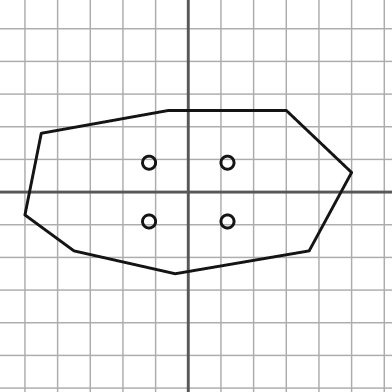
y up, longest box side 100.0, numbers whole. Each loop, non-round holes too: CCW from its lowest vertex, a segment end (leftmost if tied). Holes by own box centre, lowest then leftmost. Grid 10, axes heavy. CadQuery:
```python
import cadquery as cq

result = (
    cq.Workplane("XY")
    .moveTo(-4.0, -25.0)
    .lineTo(37.0, -18.0)
    .lineTo(50.0, 6.0)
    .lineTo(30.0, 25.0)
    .lineTo(-6.0, 25.0)
    .lineTo(-45.0, 18.0)
    .lineTo(-50.0, -7.0)
    .lineTo(-35.0, -18.0)
    .close()
    .moveTo(-12.0, -9.0)
    .circle(2.0)
    .moveTo(12.0, -9.0)
    .circle(2.0)
    .moveTo(-12.0, 9.0)
    .circle(2.0)
    .moveTo(12.0, 9.0)
    .circle(2.0)
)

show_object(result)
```